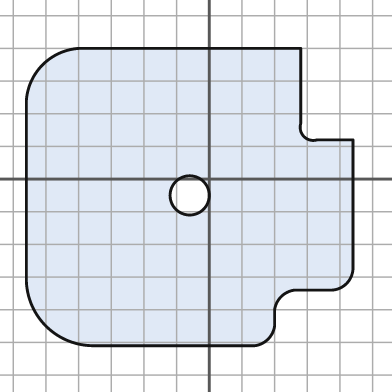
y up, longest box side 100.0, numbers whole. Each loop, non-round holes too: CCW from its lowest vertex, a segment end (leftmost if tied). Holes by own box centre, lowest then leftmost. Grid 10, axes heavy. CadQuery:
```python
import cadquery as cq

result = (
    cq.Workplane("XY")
    .moveTo(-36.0, -51.0)
    .lineTo(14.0, -51.0)
    .threePointArc((18.0, -49.0), (20.0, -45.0))
    .lineTo(20.0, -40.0)
    .threePointArc((22.0, -36.0), (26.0, -34.0))
    .lineTo(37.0, -34.0)
    .threePointArc((42.0, -32.0), (44.0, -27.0))
    .lineTo(44.0, 12.0)
    .lineTo(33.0, 12.0)
    .threePointArc((29.0, 13.0), (28.0, 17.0))
    .lineTo(28.0, 40.0)
    .lineTo(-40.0, 40.0)
    .threePointArc((-51.0, 35.0), (-56.0, 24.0))
    .lineTo(-56.0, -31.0)
    .threePointArc((-50.0, -45.0), (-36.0, -51.0))
    .close()
    .moveTo(-6.0, -5.0)
    .circle(6.0)
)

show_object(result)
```